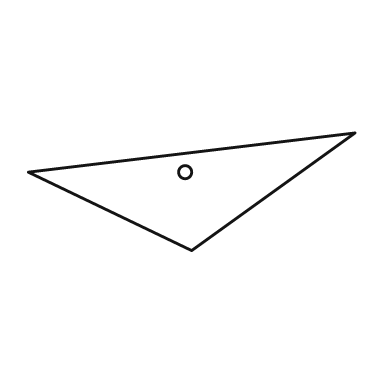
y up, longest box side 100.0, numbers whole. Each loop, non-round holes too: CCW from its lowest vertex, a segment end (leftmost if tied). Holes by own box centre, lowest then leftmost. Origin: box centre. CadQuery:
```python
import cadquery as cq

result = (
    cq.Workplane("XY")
    .moveTo(0.0, -18.0)
    .lineTo(50.0, 18.0)
    .lineTo(-50.0, 6.0)
    .close()
    .moveTo(-2.0, 6.0)
    .circle(2.0)
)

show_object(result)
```